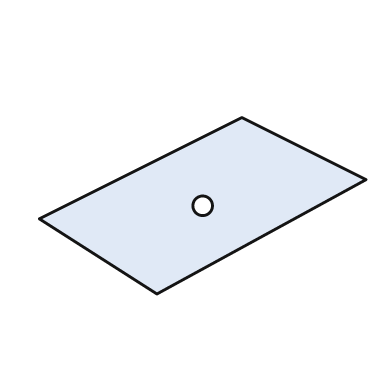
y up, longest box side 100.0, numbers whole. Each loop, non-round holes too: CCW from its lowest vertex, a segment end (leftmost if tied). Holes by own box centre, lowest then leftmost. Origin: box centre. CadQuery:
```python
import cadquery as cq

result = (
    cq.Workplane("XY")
    .moveTo(-14.0, -27.0)
    .lineTo(50.0, 8.0)
    .lineTo(12.0, 27.0)
    .lineTo(-50.0, -4.0)
    .close()
    .moveTo(0.0, 0.0)
    .circle(3.0)
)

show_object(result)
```